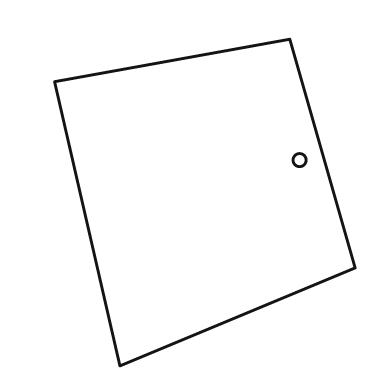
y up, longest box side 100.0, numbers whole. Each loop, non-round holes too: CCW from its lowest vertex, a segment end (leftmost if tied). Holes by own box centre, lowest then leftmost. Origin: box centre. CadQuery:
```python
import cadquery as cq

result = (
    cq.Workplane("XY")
    .moveTo(-26.0, -50.0)
    .lineTo(46.0, -20.0)
    .lineTo(26.0, 50.0)
    .lineTo(-46.0, 37.0)
    .close()
    .moveTo(29.0, 13.0)
    .circle(2.0)
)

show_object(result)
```